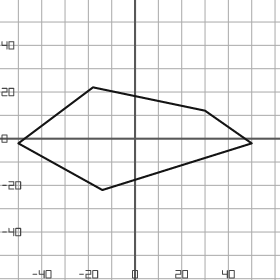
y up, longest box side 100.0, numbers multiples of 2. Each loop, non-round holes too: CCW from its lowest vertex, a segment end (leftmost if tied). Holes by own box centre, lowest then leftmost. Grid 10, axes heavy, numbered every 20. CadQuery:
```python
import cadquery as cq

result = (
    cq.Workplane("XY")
    .moveTo(-14.0, -22.0)
    .lineTo(50.0, -2.0)
    .lineTo(30.0, 12.0)
    .lineTo(-18.0, 22.0)
    .lineTo(-50.0, -2.0)
    .close()
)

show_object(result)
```